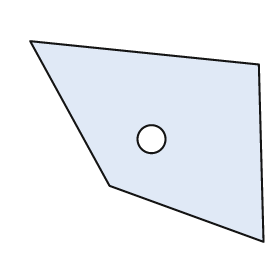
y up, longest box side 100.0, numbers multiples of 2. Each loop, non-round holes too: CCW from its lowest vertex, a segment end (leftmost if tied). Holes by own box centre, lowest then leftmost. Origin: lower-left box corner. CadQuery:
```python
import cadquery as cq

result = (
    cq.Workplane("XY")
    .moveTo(100.0, 0.0)
    .lineTo(98.0, 76.0)
    .lineTo(0.0, 86.0)
    .lineTo(34.0, 24.0)
    .close()
    .moveTo(52.0, 44.0)
    .circle(6.0)
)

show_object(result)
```